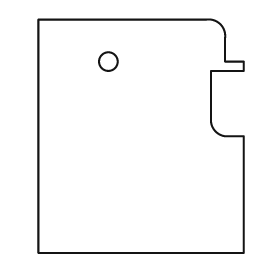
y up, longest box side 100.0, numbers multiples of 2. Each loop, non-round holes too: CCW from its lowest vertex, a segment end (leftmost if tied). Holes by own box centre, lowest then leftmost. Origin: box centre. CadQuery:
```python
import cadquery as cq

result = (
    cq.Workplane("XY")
    .moveTo(-44.0, -50.0)
    .lineTo(44.0, -50.0)
    .lineTo(44.0, 0.0)
    .lineTo(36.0, 0.0)
    .threePointArc((32.0, 2.0), (30.0, 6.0))
    .lineTo(30.0, 28.0)
    .lineTo(44.0, 28.0)
    .lineTo(44.0, 32.0)
    .lineTo(36.0, 32.0)
    .lineTo(36.0, 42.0)
    .threePointArc((34.0, 48.0), (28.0, 50.0))
    .lineTo(-44.0, 50.0)
    .close()
    .moveTo(-14.0, 32.0)
    .circle(4.0)
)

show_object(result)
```